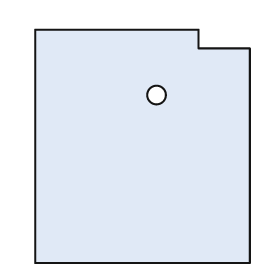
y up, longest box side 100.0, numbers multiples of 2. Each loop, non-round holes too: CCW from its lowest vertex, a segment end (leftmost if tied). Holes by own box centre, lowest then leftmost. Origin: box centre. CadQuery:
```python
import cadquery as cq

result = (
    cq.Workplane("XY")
    .moveTo(-46.0, -50.0)
    .lineTo(46.0, -50.0)
    .lineTo(46.0, 42.0)
    .lineTo(24.0, 42.0)
    .lineTo(24.0, 50.0)
    .lineTo(-46.0, 50.0)
    .close()
    .moveTo(6.0, 22.0)
    .circle(4.0)
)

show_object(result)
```